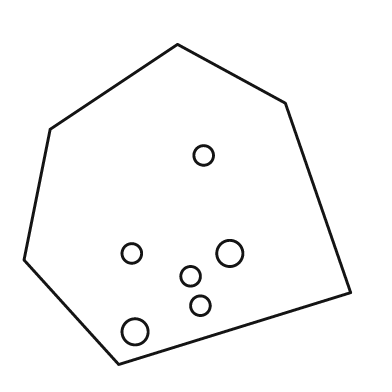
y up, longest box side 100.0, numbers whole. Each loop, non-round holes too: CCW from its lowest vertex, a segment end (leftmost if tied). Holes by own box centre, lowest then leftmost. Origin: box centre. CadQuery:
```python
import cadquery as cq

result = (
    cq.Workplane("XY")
    .moveTo(-21.0, -49.0)
    .lineTo(50.0, -27.0)
    .lineTo(30.0, 31.0)
    .lineTo(-3.0, 49.0)
    .lineTo(-42.0, 23.0)
    .lineTo(-50.0, -17.0)
    .close()
    .moveTo(-16.0, -39.0)
    .circle(4.0)
    .moveTo(4.0, -31.0)
    .circle(3.0)
    .moveTo(1.0, -22.0)
    .circle(3.0)
    .moveTo(-17.0, -15.0)
    .circle(3.0)
    .moveTo(13.0, -15.0)
    .circle(4.0)
    .moveTo(5.0, 15.0)
    .circle(3.0)
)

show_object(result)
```